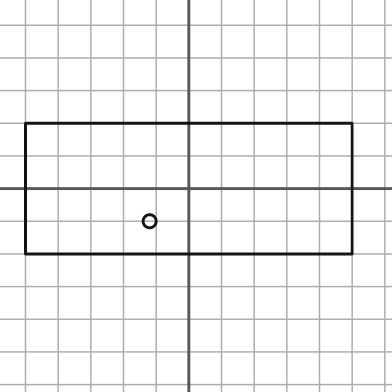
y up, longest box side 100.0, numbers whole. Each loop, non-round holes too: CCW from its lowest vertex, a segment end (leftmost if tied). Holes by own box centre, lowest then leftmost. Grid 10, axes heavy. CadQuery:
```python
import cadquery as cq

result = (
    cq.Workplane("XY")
    .moveTo(-50.0, -20.0)
    .lineTo(50.0, -20.0)
    .lineTo(50.0, 20.0)
    .lineTo(-50.0, 20.0)
    .close()
    .moveTo(-12.0, -10.0)
    .circle(2.0)
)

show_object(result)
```